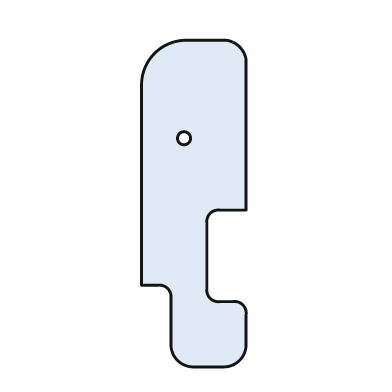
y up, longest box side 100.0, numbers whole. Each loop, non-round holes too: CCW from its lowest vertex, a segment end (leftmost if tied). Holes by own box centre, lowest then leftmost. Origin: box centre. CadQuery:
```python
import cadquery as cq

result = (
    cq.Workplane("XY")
    .moveTo(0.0, -50.0)
    .lineTo(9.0, -50.0)
    .threePointArc((14.0, -48.0), (16.0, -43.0))
    .lineTo(16.0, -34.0)
    .threePointArc((15.0, -31.0), (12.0, -30.0))
    .lineTo(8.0, -30.0)
    .threePointArc((5.0, -29.0), (4.0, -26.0))
    .lineTo(4.0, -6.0)
    .threePointArc((5.0, -3.0), (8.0, -2.0))
    .lineTo(16.0, -2.0)
    .lineTo(16.0, 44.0)
    .threePointArc((14.0, 48.0), (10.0, 50.0))
    .lineTo(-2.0, 50.0)
    .threePointArc((-12.0, 46.0), (-16.0, 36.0))
    .lineTo(-16.0, -25.0)
    .lineTo(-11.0, -25.0)
    .threePointArc((-8.0, -26.0), (-7.0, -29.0))
    .lineTo(-7.0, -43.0)
    .threePointArc((-5.0, -48.0), (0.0, -50.0))
    .close()
    .moveTo(-3.0, 20.0)
    .circle(2.0)
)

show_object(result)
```